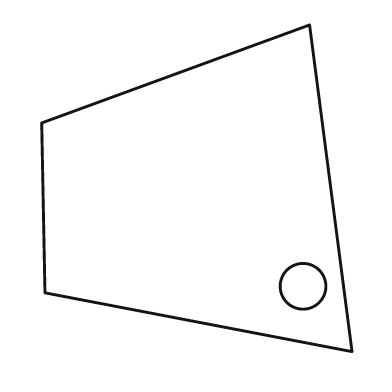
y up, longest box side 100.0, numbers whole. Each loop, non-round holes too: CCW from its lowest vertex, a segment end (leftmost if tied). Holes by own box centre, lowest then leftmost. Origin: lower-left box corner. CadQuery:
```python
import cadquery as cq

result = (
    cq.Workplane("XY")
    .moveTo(95.0, 0.0)
    .lineTo(82.0, 100.0)
    .lineTo(0.0, 70.0)
    .lineTo(1.0, 18.0)
    .close()
    .moveTo(80.0, 20.0)
    .circle(7.0)
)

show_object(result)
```